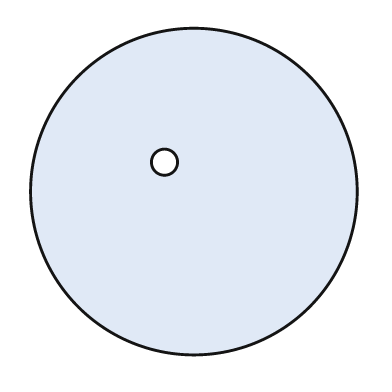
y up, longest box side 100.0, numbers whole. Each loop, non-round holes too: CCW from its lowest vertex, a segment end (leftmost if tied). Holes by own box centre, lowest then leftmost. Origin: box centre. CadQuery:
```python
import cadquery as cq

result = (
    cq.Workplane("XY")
    .moveTo(0.0, 0.0)
    .circle(50.0)
    .moveTo(-9.0, 9.0)
    .circle(4.0)
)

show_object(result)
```